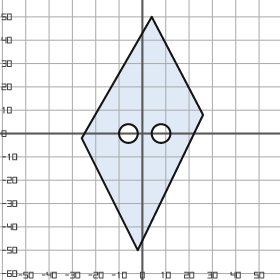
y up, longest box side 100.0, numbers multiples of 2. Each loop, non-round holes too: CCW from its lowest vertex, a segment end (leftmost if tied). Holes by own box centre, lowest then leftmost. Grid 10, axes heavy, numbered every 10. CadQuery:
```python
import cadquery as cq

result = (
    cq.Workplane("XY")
    .moveTo(-2.0, -50.0)
    .lineTo(26.0, 8.0)
    .lineTo(4.0, 50.0)
    .lineTo(-26.0, -2.0)
    .close()
    .moveTo(-6.0, 0.0)
    .circle(4.0)
    .moveTo(8.0, 0.0)
    .circle(4.0)
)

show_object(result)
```